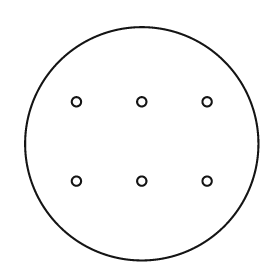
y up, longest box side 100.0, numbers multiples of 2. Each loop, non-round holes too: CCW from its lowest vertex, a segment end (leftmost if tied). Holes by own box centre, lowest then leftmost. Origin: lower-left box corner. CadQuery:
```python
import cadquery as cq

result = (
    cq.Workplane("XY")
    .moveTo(50.0, 50.0)
    .circle(50.0)
    .moveTo(22.0, 34.0)
    .circle(2.0)
    .moveTo(50.0, 34.0)
    .circle(2.0)
    .moveTo(78.0, 34.0)
    .circle(2.0)
    .moveTo(22.0, 68.0)
    .circle(2.0)
    .moveTo(50.0, 68.0)
    .circle(2.0)
    .moveTo(78.0, 68.0)
    .circle(2.0)
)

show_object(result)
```